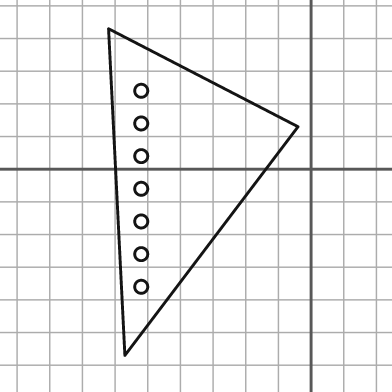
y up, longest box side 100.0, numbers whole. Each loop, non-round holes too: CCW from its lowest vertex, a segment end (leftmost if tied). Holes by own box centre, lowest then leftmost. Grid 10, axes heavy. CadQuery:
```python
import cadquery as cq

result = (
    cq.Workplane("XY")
    .moveTo(-57.0, -57.0)
    .lineTo(-4.0, 13.0)
    .lineTo(-62.0, 43.0)
    .close()
    .moveTo(-52.0, -36.0)
    .circle(2.0)
    .moveTo(-52.0, -26.0)
    .circle(2.0)
    .moveTo(-52.0, -16.0)
    .circle(2.0)
    .moveTo(-52.0, -6.0)
    .circle(2.0)
    .moveTo(-52.0, 4.0)
    .circle(2.0)
    .moveTo(-52.0, 14.0)
    .circle(2.0)
    .moveTo(-52.0, 24.0)
    .circle(2.0)
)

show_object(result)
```